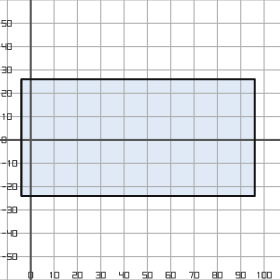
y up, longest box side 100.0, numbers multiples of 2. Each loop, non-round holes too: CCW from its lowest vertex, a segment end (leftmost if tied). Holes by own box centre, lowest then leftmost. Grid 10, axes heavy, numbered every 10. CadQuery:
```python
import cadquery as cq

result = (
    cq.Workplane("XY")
    .moveTo(-4.0, -24.0)
    .lineTo(96.0, -24.0)
    .lineTo(96.0, 26.0)
    .lineTo(-4.0, 26.0)
    .close()
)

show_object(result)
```